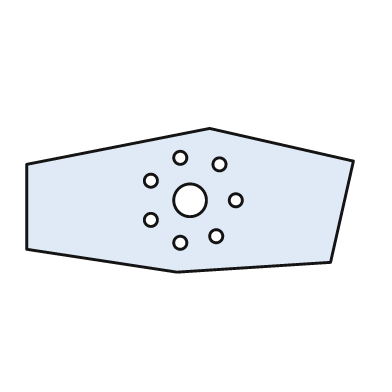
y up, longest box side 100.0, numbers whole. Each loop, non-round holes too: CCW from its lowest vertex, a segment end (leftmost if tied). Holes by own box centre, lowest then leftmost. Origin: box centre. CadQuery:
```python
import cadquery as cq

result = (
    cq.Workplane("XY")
    .moveTo(-4.0, -22.0)
    .lineTo(43.0, -19.0)
    .lineTo(50.0, 12.0)
    .lineTo(6.0, 22.0)
    .lineTo(-50.0, 11.0)
    .lineTo(-50.0, -15.0)
    .close()
    .moveTo(-3.0, -13.0)
    .circle(2.0)
    .moveTo(8.0, -11.0)
    .circle(2.0)
    .moveTo(-12.0, -6.0)
    .circle(2.0)
    .moveTo(0.0, 0.0)
    .circle(5.0)
    .moveTo(14.0, 0.0)
    .circle(2.0)
    .moveTo(-12.0, 6.0)
    .circle(2.0)
    .moveTo(9.0, 11.0)
    .circle(2.0)
    .moveTo(-3.0, 13.0)
    .circle(2.0)
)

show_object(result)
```